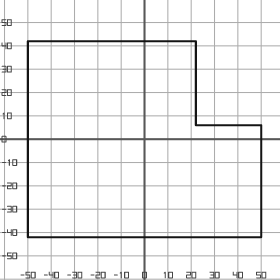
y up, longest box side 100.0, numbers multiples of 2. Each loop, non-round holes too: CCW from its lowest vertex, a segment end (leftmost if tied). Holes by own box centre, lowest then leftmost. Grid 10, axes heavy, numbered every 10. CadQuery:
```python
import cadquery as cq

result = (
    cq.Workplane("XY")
    .moveTo(-50.0, -42.0)
    .lineTo(50.0, -42.0)
    .lineTo(50.0, 6.0)
    .lineTo(22.0, 6.0)
    .lineTo(22.0, 42.0)
    .lineTo(-50.0, 42.0)
    .close()
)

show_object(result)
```